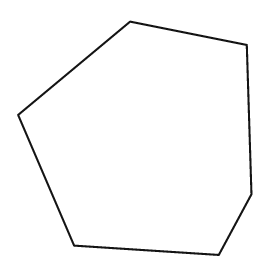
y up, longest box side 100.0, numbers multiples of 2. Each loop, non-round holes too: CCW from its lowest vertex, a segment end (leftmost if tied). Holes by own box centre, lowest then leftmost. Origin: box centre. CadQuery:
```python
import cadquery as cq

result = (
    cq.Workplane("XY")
    .moveTo(36.0, -50.0)
    .lineTo(50.0, -24.0)
    .lineTo(48.0, 40.0)
    .lineTo(-2.0, 50.0)
    .lineTo(-50.0, 10.0)
    .lineTo(-26.0, -46.0)
    .close()
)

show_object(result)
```